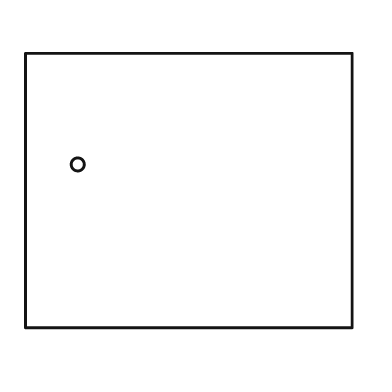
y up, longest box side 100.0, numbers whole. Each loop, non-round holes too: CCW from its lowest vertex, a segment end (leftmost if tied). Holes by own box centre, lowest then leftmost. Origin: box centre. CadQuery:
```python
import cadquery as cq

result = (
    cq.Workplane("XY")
    .moveTo(-50.0, -42.0)
    .lineTo(50.0, -42.0)
    .lineTo(50.0, 42.0)
    .lineTo(-50.0, 42.0)
    .close()
    .moveTo(-34.0, 8.0)
    .circle(2.0)
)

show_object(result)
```